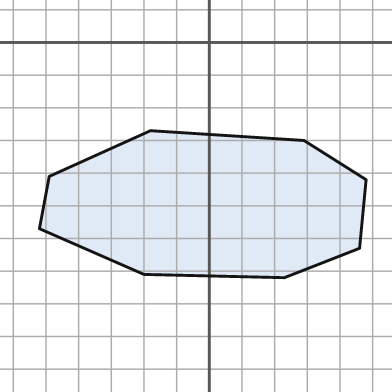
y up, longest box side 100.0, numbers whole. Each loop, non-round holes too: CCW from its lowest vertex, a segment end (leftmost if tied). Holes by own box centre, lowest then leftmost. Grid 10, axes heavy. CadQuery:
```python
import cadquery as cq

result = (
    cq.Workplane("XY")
    .moveTo(23.0, -72.0)
    .lineTo(46.0, -63.0)
    .lineTo(48.0, -42.0)
    .lineTo(29.0, -30.0)
    .lineTo(-18.0, -27.0)
    .lineTo(-49.0, -41.0)
    .lineTo(-52.0, -57.0)
    .lineTo(-20.0, -71.0)
    .close()
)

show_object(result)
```